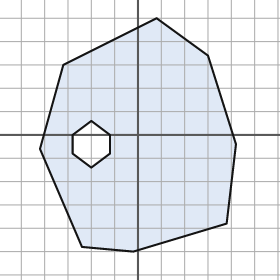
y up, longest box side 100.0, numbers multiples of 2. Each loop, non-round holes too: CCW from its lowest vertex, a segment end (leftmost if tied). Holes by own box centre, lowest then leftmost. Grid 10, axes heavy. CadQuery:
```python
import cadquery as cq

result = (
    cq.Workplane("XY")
    .moveTo(-2.0, -50.0)
    .lineTo(38.0, -38.0)
    .lineTo(42.0, -4.0)
    .lineTo(30.0, 34.0)
    .lineTo(8.0, 50.0)
    .lineTo(-32.0, 30.0)
    .lineTo(-42.0, -6.0)
    .lineTo(-24.0, -48.0)
    .close()
    .moveTo(-20.0, -14.0)
    .lineTo(-12.0, -8.0)
    .lineTo(-12.0, 0.0)
    .lineTo(-20.0, 6.0)
    .lineTo(-28.0, 0.0)
    .lineTo(-28.0, -8.0)
    .close()
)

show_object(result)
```